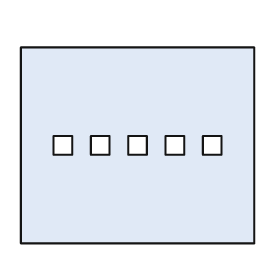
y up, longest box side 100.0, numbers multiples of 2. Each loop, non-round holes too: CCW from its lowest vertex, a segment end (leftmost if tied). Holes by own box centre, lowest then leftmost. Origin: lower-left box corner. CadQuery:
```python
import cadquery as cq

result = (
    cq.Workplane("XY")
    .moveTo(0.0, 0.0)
    .lineTo(100.0, 0.0)
    .lineTo(100.0, 84.0)
    .lineTo(0.0, 84.0)
    .close()
    .moveTo(14.0, 38.0)
    .lineTo(22.0, 38.0)
    .lineTo(22.0, 46.0)
    .lineTo(14.0, 46.0)
    .close()
    .moveTo(30.0, 38.0)
    .lineTo(38.0, 38.0)
    .lineTo(38.0, 46.0)
    .lineTo(30.0, 46.0)
    .close()
    .moveTo(46.0, 38.0)
    .lineTo(54.0, 38.0)
    .lineTo(54.0, 46.0)
    .lineTo(46.0, 46.0)
    .close()
    .moveTo(62.0, 38.0)
    .lineTo(70.0, 38.0)
    .lineTo(70.0, 46.0)
    .lineTo(62.0, 46.0)
    .close()
    .moveTo(78.0, 38.0)
    .lineTo(86.0, 38.0)
    .lineTo(86.0, 46.0)
    .lineTo(78.0, 46.0)
    .close()
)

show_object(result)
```